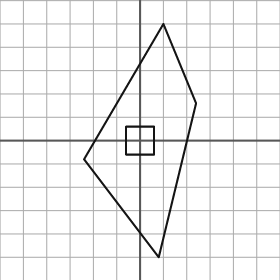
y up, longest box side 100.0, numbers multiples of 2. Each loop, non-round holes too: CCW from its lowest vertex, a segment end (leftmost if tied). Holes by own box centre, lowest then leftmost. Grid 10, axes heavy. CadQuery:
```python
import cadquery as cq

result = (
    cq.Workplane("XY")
    .moveTo(8.0, -50.0)
    .lineTo(24.0, 16.0)
    .lineTo(10.0, 50.0)
    .lineTo(-24.0, -8.0)
    .close()
    .moveTo(-6.0, -6.0)
    .lineTo(6.0, -6.0)
    .lineTo(6.0, 6.0)
    .lineTo(-6.0, 6.0)
    .close()
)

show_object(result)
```